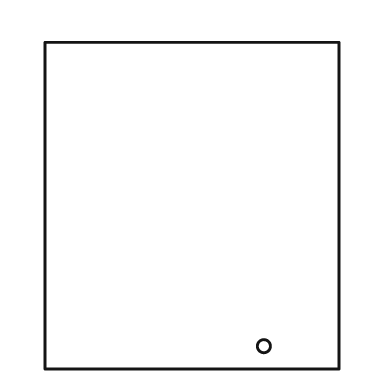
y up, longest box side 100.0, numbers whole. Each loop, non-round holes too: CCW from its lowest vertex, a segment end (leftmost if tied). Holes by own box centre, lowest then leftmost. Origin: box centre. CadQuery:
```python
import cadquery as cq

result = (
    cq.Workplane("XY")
    .moveTo(-45.0, -50.0)
    .lineTo(45.0, -50.0)
    .lineTo(45.0, 50.0)
    .lineTo(-45.0, 50.0)
    .close()
    .moveTo(22.0, -43.0)
    .circle(2.0)
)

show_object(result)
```